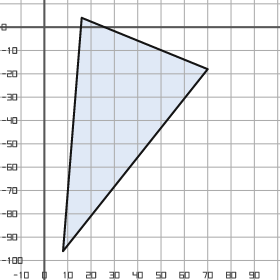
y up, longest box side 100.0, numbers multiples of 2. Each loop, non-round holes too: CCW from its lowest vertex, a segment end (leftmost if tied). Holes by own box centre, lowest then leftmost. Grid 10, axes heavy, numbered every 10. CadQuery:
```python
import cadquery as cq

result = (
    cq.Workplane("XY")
    .moveTo(8.0, -96.0)
    .lineTo(70.0, -18.0)
    .lineTo(16.0, 4.0)
    .close()
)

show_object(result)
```